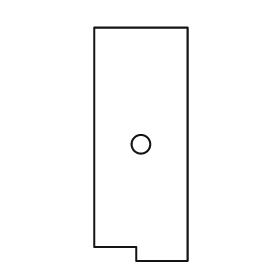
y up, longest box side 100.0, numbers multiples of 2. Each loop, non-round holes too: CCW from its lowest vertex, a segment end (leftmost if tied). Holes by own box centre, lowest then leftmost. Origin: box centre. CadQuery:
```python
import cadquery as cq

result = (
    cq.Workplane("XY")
    .moveTo(-2.0, -50.0)
    .lineTo(20.0, -50.0)
    .lineTo(20.0, 50.0)
    .lineTo(-20.0, 50.0)
    .lineTo(-20.0, -44.0)
    .lineTo(-2.0, -44.0)
    .close()
    .moveTo(0.0, 0.0)
    .circle(4.0)
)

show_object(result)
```